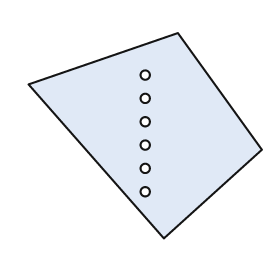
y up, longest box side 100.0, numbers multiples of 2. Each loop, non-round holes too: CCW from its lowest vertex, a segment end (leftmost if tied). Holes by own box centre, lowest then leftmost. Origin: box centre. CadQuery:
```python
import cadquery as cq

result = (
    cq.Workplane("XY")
    .moveTo(8.0, -44.0)
    .lineTo(50.0, -6.0)
    .lineTo(14.0, 44.0)
    .lineTo(-50.0, 22.0)
    .close()
    .moveTo(0.0, -24.0)
    .circle(2.0)
    .moveTo(0.0, -14.0)
    .circle(2.0)
    .moveTo(0.0, -4.0)
    .circle(2.0)
    .moveTo(0.0, 6.0)
    .circle(2.0)
    .moveTo(0.0, 16.0)
    .circle(2.0)
    .moveTo(0.0, 26.0)
    .circle(2.0)
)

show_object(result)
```